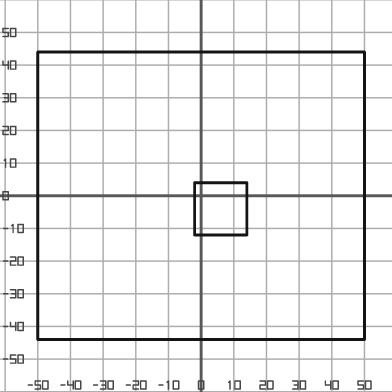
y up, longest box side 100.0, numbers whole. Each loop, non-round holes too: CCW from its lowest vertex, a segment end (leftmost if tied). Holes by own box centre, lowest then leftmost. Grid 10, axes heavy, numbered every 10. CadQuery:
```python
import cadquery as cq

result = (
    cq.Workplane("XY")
    .moveTo(-50.0, -44.0)
    .lineTo(50.0, -44.0)
    .lineTo(50.0, 44.0)
    .lineTo(-50.0, 44.0)
    .close()
    .moveTo(-2.0, -12.0)
    .lineTo(14.0, -12.0)
    .lineTo(14.0, 4.0)
    .lineTo(-2.0, 4.0)
    .close()
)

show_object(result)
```